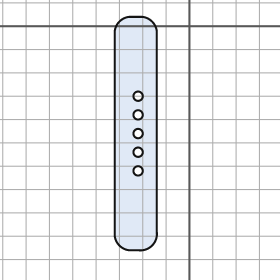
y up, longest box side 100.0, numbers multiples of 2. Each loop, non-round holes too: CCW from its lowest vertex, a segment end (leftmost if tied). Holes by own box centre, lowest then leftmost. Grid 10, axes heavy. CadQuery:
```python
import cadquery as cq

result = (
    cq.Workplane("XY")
    .moveTo(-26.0, -96.0)
    .lineTo(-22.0, -96.0)
    .threePointArc((-16.0, -94.0), (-14.0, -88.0))
    .lineTo(-14.0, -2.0)
    .threePointArc((-16.0, 2.0), (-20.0, 4.0))
    .lineTo(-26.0, 4.0)
    .threePointArc((-30.0, 2.0), (-32.0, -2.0))
    .lineTo(-32.0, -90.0)
    .threePointArc((-30.0, -94.0), (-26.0, -96.0))
    .close()
    .moveTo(-22.0, -62.0)
    .circle(2.0)
    .moveTo(-22.0, -54.0)
    .circle(2.0)
    .moveTo(-22.0, -46.0)
    .circle(2.0)
    .moveTo(-22.0, -38.0)
    .circle(2.0)
    .moveTo(-22.0, -30.0)
    .circle(2.0)
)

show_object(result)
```